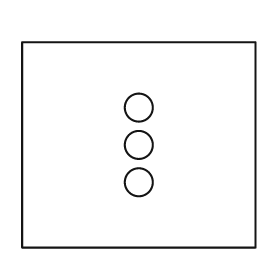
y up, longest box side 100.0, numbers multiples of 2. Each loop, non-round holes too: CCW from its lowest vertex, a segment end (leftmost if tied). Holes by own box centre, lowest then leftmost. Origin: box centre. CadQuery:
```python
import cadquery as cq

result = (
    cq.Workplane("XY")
    .moveTo(-50.0, -44.0)
    .lineTo(50.0, -44.0)
    .lineTo(50.0, 44.0)
    .lineTo(-50.0, 44.0)
    .close()
    .moveTo(0.0, -16.0)
    .circle(6.0)
    .moveTo(0.0, 0.0)
    .circle(6.0)
    .moveTo(0.0, 16.0)
    .circle(6.0)
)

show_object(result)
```